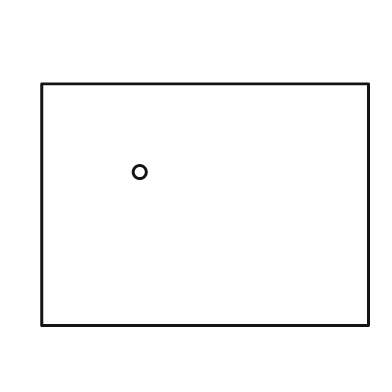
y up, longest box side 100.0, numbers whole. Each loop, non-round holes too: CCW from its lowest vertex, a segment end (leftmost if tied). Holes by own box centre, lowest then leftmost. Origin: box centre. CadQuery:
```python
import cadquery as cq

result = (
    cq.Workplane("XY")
    .moveTo(-50.0, -37.0)
    .lineTo(50.0, -37.0)
    .lineTo(50.0, 37.0)
    .lineTo(-50.0, 37.0)
    .close()
    .moveTo(-20.0, 10.0)
    .circle(2.0)
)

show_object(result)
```